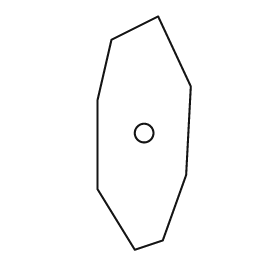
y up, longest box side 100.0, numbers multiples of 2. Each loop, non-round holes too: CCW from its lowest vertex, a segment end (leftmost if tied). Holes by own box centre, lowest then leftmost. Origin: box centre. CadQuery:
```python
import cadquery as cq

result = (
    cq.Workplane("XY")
    .moveTo(-4.0, -50.0)
    .lineTo(8.0, -46.0)
    .lineTo(18.0, -18.0)
    .lineTo(20.0, 20.0)
    .lineTo(6.0, 50.0)
    .lineTo(-14.0, 40.0)
    .lineTo(-20.0, 14.0)
    .lineTo(-20.0, -24.0)
    .close()
    .moveTo(0.0, 0.0)
    .circle(4.0)
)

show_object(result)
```